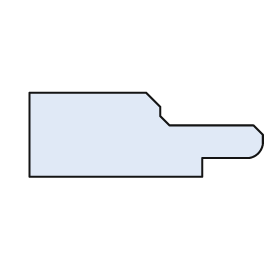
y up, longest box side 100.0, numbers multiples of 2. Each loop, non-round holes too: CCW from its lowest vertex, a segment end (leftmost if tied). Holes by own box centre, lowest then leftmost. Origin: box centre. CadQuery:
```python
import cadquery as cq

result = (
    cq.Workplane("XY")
    .moveTo(-50.0, -18.0)
    .lineTo(24.0, -18.0)
    .lineTo(24.0, -10.0)
    .lineTo(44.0, -10.0)
    .threePointArc((48.0, -8.0), (50.0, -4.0))
    .lineTo(50.0, 0.0)
    .lineTo(46.0, 4.0)
    .lineTo(10.0, 4.0)
    .lineTo(6.0, 8.0)
    .lineTo(6.0, 12.0)
    .lineTo(0.0, 18.0)
    .lineTo(-50.0, 18.0)
    .close()
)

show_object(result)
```